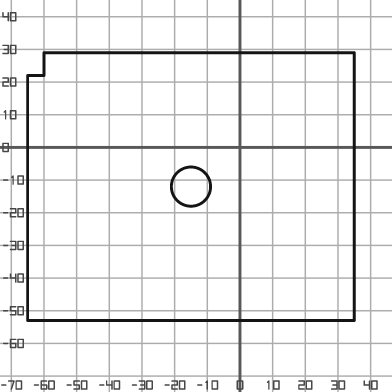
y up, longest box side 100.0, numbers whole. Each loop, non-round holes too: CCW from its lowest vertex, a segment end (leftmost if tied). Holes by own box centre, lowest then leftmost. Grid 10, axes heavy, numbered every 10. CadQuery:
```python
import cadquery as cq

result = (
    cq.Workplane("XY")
    .moveTo(-65.0, -53.0)
    .lineTo(35.0, -53.0)
    .lineTo(35.0, 29.0)
    .lineTo(-60.0, 29.0)
    .lineTo(-60.0, 22.0)
    .lineTo(-65.0, 22.0)
    .close()
    .moveTo(-15.0, -12.0)
    .circle(6.0)
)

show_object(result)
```